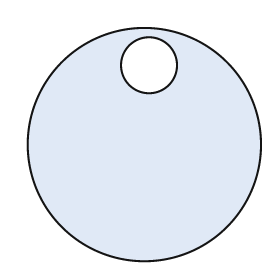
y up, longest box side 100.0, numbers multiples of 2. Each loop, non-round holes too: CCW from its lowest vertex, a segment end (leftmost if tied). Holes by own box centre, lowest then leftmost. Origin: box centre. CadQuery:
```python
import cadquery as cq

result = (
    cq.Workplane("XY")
    .moveTo(0.0, 0.0)
    .circle(50.0)
    .moveTo(2.0, 34.0)
    .circle(12.0)
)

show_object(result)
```